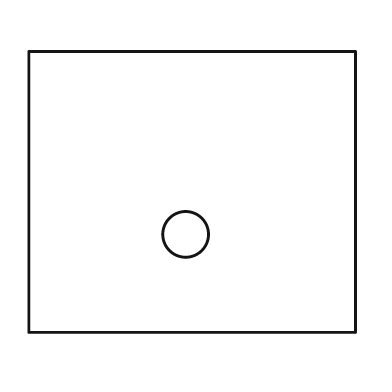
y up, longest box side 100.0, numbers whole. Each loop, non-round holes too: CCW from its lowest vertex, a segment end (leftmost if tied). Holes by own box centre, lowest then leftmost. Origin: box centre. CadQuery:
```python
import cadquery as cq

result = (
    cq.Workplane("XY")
    .moveTo(-50.0, -43.0)
    .lineTo(50.0, -43.0)
    .lineTo(50.0, 43.0)
    .lineTo(-50.0, 43.0)
    .close()
    .moveTo(-2.0, -13.0)
    .circle(7.0)
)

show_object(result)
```